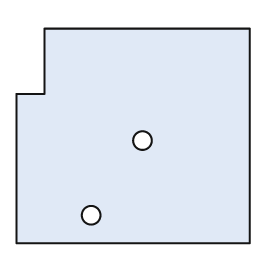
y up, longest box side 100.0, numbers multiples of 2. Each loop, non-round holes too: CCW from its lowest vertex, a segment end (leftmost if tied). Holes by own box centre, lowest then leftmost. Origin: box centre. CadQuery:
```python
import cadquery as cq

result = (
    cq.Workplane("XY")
    .moveTo(-50.0, -46.0)
    .lineTo(50.0, -46.0)
    .lineTo(50.0, 46.0)
    .lineTo(-38.0, 46.0)
    .lineTo(-38.0, 18.0)
    .lineTo(-50.0, 18.0)
    .close()
    .moveTo(-18.0, -34.0)
    .circle(4.0)
    .moveTo(4.0, -2.0)
    .circle(4.0)
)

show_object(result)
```